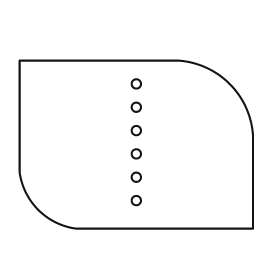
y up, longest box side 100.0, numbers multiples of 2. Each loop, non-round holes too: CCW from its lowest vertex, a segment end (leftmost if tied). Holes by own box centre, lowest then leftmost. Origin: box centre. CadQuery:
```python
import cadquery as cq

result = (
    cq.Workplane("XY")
    .moveTo(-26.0, -36.0)
    .lineTo(50.0, -36.0)
    .lineTo(50.0, 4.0)
    .threePointArc((40.0, 26.0), (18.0, 36.0))
    .lineTo(-50.0, 36.0)
    .lineTo(-50.0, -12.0)
    .threePointArc((-42.0, -28.0), (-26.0, -36.0))
    .close()
    .moveTo(0.0, -24.0)
    .circle(2.0)
    .moveTo(0.0, -14.0)
    .circle(2.0)
    .moveTo(0.0, -4.0)
    .circle(2.0)
    .moveTo(0.0, 6.0)
    .circle(2.0)
    .moveTo(0.0, 16.0)
    .circle(2.0)
    .moveTo(0.0, 26.0)
    .circle(2.0)
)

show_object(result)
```